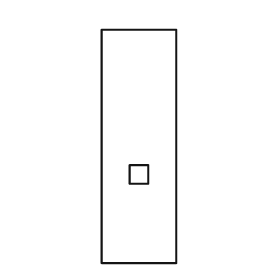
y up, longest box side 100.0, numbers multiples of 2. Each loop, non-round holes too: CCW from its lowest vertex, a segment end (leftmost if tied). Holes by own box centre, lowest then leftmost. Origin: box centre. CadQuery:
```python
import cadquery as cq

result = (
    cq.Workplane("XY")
    .moveTo(-16.0, -50.0)
    .lineTo(16.0, -50.0)
    .lineTo(16.0, 50.0)
    .lineTo(-16.0, 50.0)
    .close()
    .moveTo(-4.0, -16.0)
    .lineTo(4.0, -16.0)
    .lineTo(4.0, -8.0)
    .lineTo(-4.0, -8.0)
    .close()
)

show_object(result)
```